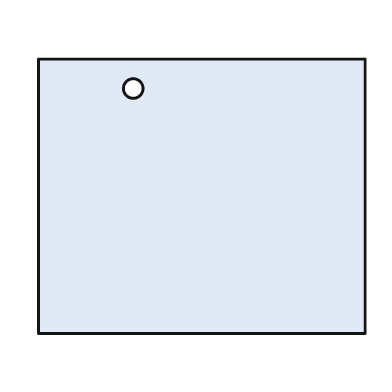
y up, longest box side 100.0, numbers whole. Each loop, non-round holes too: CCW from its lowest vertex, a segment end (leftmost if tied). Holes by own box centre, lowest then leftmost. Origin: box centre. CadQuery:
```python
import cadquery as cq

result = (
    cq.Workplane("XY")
    .moveTo(-50.0, -42.0)
    .lineTo(50.0, -42.0)
    .lineTo(50.0, 42.0)
    .lineTo(-50.0, 42.0)
    .close()
    .moveTo(-21.0, 33.0)
    .circle(3.0)
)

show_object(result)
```